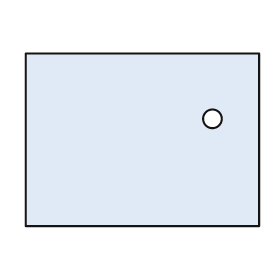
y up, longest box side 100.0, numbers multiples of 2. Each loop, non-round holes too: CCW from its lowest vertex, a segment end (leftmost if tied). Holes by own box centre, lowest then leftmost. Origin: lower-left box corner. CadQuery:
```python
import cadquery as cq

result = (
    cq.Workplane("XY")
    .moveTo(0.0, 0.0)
    .lineTo(100.0, 0.0)
    .lineTo(100.0, 74.0)
    .lineTo(0.0, 74.0)
    .close()
    .moveTo(80.0, 46.0)
    .circle(4.0)
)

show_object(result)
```